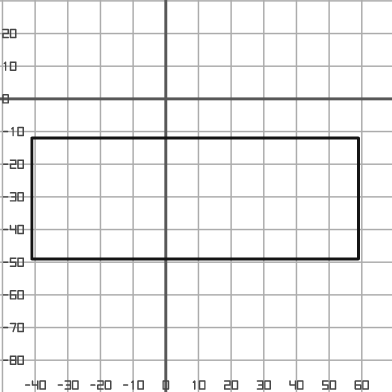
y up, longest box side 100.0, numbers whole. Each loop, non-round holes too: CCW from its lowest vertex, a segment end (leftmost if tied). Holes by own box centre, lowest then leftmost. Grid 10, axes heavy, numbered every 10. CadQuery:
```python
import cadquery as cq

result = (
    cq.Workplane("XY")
    .moveTo(-41.0, -49.0)
    .lineTo(59.0, -49.0)
    .lineTo(59.0, -12.0)
    .lineTo(-41.0, -12.0)
    .close()
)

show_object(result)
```